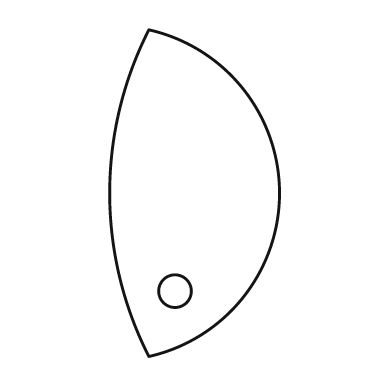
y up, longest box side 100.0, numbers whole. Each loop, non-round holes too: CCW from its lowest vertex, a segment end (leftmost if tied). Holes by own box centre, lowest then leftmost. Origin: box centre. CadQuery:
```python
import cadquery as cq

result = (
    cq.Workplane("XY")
    .moveTo(-14.0, -50.0)
    .threePointArc((26.0, 0.0), (-14.0, 50.0))
    .threePointArc((-26.0, 0.0), (-14.0, -50.0))
    .close()
    .moveTo(-6.0, -30.0)
    .circle(5.0)
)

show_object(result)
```